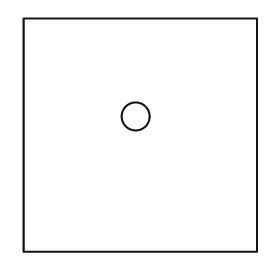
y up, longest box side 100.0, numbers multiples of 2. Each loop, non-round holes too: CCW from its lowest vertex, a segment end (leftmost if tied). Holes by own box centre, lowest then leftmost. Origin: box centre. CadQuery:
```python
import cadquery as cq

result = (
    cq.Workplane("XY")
    .moveTo(-50.0, -50.0)
    .lineTo(50.0, -50.0)
    .lineTo(50.0, 50.0)
    .lineTo(-50.0, 50.0)
    .close()
    .moveTo(-2.0, 8.0)
    .circle(6.0)
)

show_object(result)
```